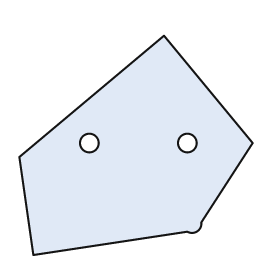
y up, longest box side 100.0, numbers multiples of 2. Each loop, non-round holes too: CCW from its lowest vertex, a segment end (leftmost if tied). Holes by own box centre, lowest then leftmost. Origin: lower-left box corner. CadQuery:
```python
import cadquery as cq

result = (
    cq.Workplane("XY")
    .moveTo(6.0, 0.0)
    .lineTo(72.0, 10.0)
    .threePointArc((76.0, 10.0), (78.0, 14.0))
    .lineTo(100.0, 48.0)
    .lineTo(62.0, 94.0)
    .lineTo(0.0, 42.0)
    .close()
    .moveTo(30.0, 48.0)
    .circle(4.0)
    .moveTo(72.0, 48.0)
    .circle(4.0)
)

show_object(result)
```